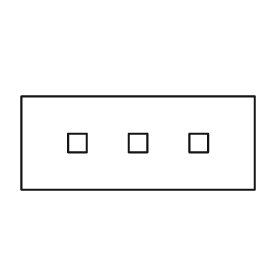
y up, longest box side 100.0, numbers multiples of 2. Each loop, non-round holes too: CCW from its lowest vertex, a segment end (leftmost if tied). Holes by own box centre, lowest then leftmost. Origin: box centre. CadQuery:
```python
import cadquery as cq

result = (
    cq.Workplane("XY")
    .moveTo(-50.0, -20.0)
    .lineTo(50.0, -20.0)
    .lineTo(50.0, 20.0)
    .lineTo(-50.0, 20.0)
    .close()
    .moveTo(-30.0, -4.0)
    .lineTo(-22.0, -4.0)
    .lineTo(-22.0, 4.0)
    .lineTo(-30.0, 4.0)
    .close()
    .moveTo(-4.0, -4.0)
    .lineTo(4.0, -4.0)
    .lineTo(4.0, 4.0)
    .lineTo(-4.0, 4.0)
    .close()
    .moveTo(22.0, -4.0)
    .lineTo(30.0, -4.0)
    .lineTo(30.0, 4.0)
    .lineTo(22.0, 4.0)
    .close()
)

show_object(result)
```